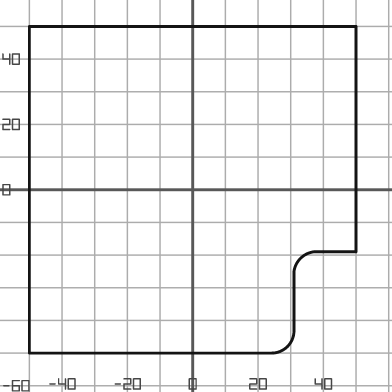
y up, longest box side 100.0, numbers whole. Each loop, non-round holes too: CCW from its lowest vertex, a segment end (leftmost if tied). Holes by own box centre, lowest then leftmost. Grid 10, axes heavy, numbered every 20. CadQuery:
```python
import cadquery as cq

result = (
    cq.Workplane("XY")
    .moveTo(-50.0, -50.0)
    .lineTo(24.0, -50.0)
    .threePointArc((29.0, -48.0), (31.0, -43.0))
    .lineTo(31.0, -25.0)
    .threePointArc((33.0, -21.0), (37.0, -19.0))
    .lineTo(50.0, -19.0)
    .lineTo(50.0, 50.0)
    .lineTo(-50.0, 50.0)
    .close()
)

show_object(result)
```